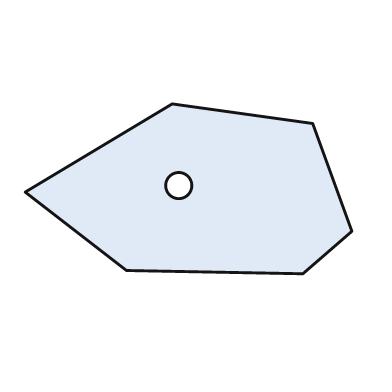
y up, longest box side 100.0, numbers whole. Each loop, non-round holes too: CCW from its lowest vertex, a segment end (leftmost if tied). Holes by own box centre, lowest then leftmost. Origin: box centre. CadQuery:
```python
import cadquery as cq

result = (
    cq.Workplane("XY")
    .moveTo(35.0, -26.0)
    .lineTo(50.0, -13.0)
    .lineTo(38.0, 20.0)
    .lineTo(-5.0, 26.0)
    .lineTo(-50.0, -1.0)
    .lineTo(-19.0, -25.0)
    .close()
    .moveTo(-3.0, 1.0)
    .circle(4.0)
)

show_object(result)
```